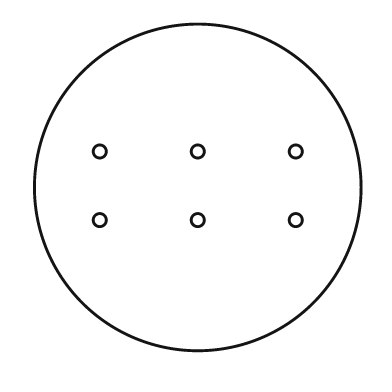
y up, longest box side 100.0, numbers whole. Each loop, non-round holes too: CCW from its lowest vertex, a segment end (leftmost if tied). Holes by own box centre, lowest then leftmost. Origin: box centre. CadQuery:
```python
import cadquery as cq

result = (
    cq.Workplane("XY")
    .moveTo(0.0, 0.0)
    .circle(50.0)
    .moveTo(-30.0, -10.0)
    .circle(2.0)
    .moveTo(0.0, -10.0)
    .circle(2.0)
    .moveTo(30.0, -10.0)
    .circle(2.0)
    .moveTo(-30.0, 11.0)
    .circle(2.0)
    .moveTo(0.0, 11.0)
    .circle(2.0)
    .moveTo(30.0, 11.0)
    .circle(2.0)
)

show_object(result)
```